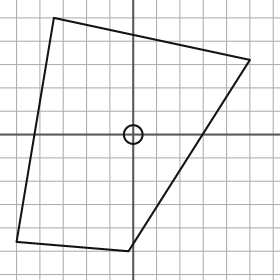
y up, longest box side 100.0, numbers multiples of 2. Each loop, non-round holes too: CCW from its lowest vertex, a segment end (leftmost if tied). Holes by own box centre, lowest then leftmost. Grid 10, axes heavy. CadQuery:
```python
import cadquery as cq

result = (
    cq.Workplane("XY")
    .moveTo(-2.0, -50.0)
    .lineTo(50.0, 32.0)
    .lineTo(-34.0, 50.0)
    .lineTo(-50.0, -46.0)
    .close()
    .moveTo(0.0, 0.0)
    .circle(4.0)
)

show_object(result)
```